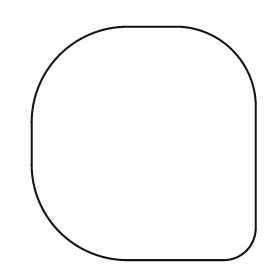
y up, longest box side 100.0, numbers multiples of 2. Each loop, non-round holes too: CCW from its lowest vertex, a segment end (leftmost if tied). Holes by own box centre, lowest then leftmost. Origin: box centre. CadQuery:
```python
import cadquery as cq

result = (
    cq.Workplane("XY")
    .moveTo(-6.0, -50.0)
    .lineTo(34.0, -50.0)
    .threePointArc((44.0, -46.0), (48.0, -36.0))
    .lineTo(48.0, 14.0)
    .threePointArc((38.0, 40.0), (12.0, 50.0))
    .lineTo(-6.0, 50.0)
    .threePointArc((-36.0, 38.0), (-48.0, 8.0))
    .lineTo(-48.0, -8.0)
    .threePointArc((-36.0, -38.0), (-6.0, -50.0))
    .close()
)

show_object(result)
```